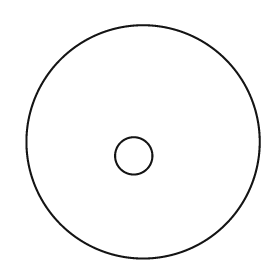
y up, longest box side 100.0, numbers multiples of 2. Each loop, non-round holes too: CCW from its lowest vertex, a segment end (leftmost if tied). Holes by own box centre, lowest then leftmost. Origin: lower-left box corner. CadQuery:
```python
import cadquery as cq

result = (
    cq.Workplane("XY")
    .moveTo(50.0, 50.0)
    .circle(50.0)
    .moveTo(46.0, 44.0)
    .circle(8.0)
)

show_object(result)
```